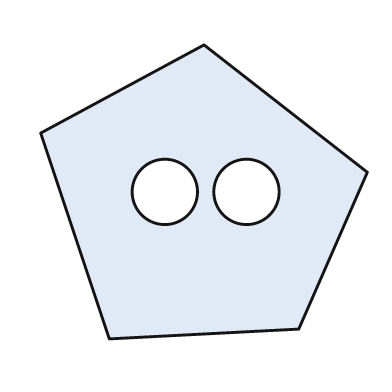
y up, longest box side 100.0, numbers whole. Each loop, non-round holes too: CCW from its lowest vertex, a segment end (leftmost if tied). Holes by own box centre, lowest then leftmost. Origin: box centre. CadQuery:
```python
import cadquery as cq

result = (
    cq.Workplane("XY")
    .moveTo(-29.0, -45.0)
    .lineTo(29.0, -42.0)
    .lineTo(50.0, 6.0)
    .lineTo(0.0, 45.0)
    .lineTo(-50.0, 18.0)
    .close()
    .moveTo(-12.0, 0.0)
    .circle(10.0)
    .moveTo(13.0, 0.0)
    .circle(10.0)
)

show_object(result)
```